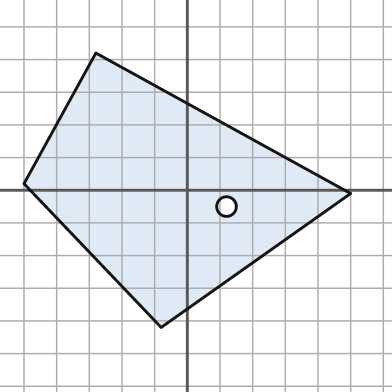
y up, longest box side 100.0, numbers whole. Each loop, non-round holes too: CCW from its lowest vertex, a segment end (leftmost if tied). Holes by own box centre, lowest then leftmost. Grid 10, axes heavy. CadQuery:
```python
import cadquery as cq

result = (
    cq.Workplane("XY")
    .moveTo(-8.0, -42.0)
    .lineTo(50.0, -1.0)
    .lineTo(-28.0, 42.0)
    .lineTo(-50.0, 2.0)
    .close()
    .moveTo(12.0, -5.0)
    .circle(3.0)
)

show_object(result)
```